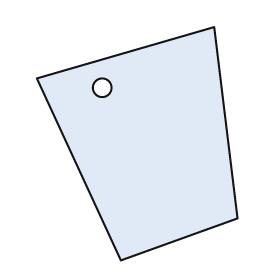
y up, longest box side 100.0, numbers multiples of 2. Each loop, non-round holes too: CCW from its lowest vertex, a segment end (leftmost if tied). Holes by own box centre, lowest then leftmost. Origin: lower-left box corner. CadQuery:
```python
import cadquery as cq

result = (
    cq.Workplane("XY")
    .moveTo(36.0, 0.0)
    .lineTo(86.0, 18.0)
    .lineTo(76.0, 100.0)
    .lineTo(0.0, 78.0)
    .close()
    .moveTo(28.0, 74.0)
    .circle(4.0)
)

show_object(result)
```